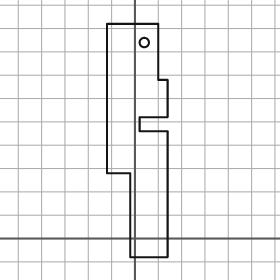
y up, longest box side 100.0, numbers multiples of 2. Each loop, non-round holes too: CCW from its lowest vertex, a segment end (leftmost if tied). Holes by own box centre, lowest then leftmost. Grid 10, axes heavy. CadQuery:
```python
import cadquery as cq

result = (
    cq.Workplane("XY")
    .moveTo(-2.0, -8.0)
    .lineTo(14.0, -8.0)
    .lineTo(14.0, 46.0)
    .lineTo(2.0, 46.0)
    .lineTo(2.0, 52.0)
    .lineTo(14.0, 52.0)
    .lineTo(14.0, 68.0)
    .lineTo(10.0, 68.0)
    .lineTo(10.0, 92.0)
    .lineTo(-12.0, 92.0)
    .lineTo(-12.0, 28.0)
    .lineTo(-2.0, 28.0)
    .close()
    .moveTo(4.0, 84.0)
    .circle(2.0)
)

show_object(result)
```